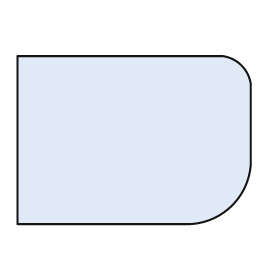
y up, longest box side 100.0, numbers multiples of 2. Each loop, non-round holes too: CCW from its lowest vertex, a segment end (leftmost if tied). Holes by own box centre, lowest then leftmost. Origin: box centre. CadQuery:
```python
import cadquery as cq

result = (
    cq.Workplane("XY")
    .moveTo(-50.0, -36.0)
    .lineTo(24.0, -36.0)
    .threePointArc((42.0, -28.0), (50.0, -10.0))
    .lineTo(50.0, 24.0)
    .threePointArc((46.0, 32.0), (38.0, 36.0))
    .lineTo(-50.0, 36.0)
    .close()
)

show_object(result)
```